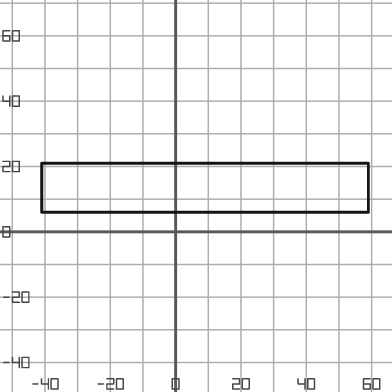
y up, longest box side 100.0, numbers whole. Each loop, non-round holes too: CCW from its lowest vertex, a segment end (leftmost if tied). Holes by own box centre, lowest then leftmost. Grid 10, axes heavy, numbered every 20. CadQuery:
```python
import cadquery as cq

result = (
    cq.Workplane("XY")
    .moveTo(-41.0, 6.0)
    .lineTo(59.0, 6.0)
    .lineTo(59.0, 21.0)
    .lineTo(-41.0, 21.0)
    .close()
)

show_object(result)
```